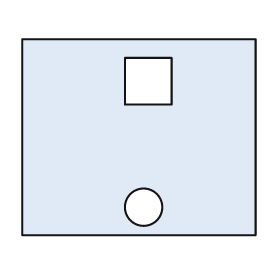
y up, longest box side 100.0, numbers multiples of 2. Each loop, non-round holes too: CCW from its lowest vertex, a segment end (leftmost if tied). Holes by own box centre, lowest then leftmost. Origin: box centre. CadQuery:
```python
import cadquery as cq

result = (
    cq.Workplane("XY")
    .moveTo(-50.0, -42.0)
    .lineTo(50.0, -42.0)
    .lineTo(50.0, 42.0)
    .lineTo(-50.0, 42.0)
    .close()
    .moveTo(2.0, -30.0)
    .circle(8.0)
    .moveTo(-6.0, 14.0)
    .lineTo(14.0, 14.0)
    .lineTo(14.0, 34.0)
    .lineTo(-6.0, 34.0)
    .close()
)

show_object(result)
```